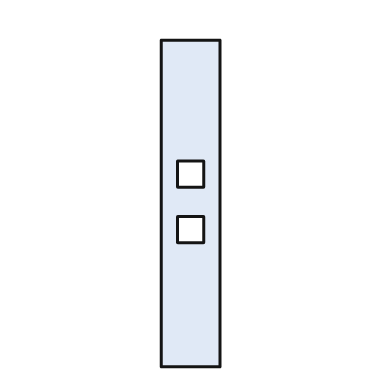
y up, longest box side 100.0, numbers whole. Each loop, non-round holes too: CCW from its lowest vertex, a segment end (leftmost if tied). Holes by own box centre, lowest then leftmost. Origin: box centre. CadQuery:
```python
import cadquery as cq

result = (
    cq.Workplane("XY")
    .moveTo(-9.0, -50.0)
    .lineTo(9.0, -50.0)
    .lineTo(9.0, 50.0)
    .lineTo(-9.0, 50.0)
    .close()
    .moveTo(-4.0, -12.0)
    .lineTo(4.0, -12.0)
    .lineTo(4.0, -4.0)
    .lineTo(-4.0, -4.0)
    .close()
    .moveTo(-4.0, 5.0)
    .lineTo(4.0, 5.0)
    .lineTo(4.0, 13.0)
    .lineTo(-4.0, 13.0)
    .close()
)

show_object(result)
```